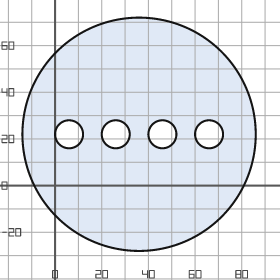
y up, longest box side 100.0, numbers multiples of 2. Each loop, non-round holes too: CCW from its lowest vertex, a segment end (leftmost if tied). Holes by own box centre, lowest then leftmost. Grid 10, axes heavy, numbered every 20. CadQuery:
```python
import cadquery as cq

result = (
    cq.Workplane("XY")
    .moveTo(36.0, 22.0)
    .circle(50.0)
    .moveTo(6.0, 22.0)
    .circle(6.0)
    .moveTo(26.0, 22.0)
    .circle(6.0)
    .moveTo(46.0, 22.0)
    .circle(6.0)
    .moveTo(66.0, 22.0)
    .circle(6.0)
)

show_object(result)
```